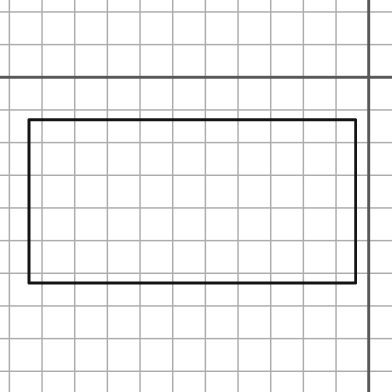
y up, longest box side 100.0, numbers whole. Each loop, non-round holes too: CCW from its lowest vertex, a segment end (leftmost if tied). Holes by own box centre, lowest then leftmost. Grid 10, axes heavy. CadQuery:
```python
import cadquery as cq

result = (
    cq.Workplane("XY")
    .moveTo(-104.0, -63.0)
    .lineTo(-4.0, -63.0)
    .lineTo(-4.0, -13.0)
    .lineTo(-104.0, -13.0)
    .close()
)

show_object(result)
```